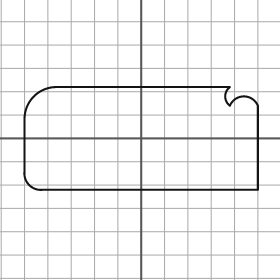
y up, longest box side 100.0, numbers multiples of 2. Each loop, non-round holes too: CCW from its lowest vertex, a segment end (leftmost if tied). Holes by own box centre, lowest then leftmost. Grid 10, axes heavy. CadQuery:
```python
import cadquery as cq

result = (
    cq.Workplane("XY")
    .moveTo(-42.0, -22.0)
    .lineTo(50.0, -22.0)
    .lineTo(50.0, 14.0)
    .threePointArc((44.0, 18.0), (38.0, 14.0))
    .threePointArc((36.0, 18.0), (38.0, 22.0))
    .lineTo(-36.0, 22.0)
    .threePointArc((-46.0, 18.0), (-50.0, 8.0))
    .lineTo(-50.0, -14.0)
    .threePointArc((-48.0, -20.0), (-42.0, -22.0))
    .close()
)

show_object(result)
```